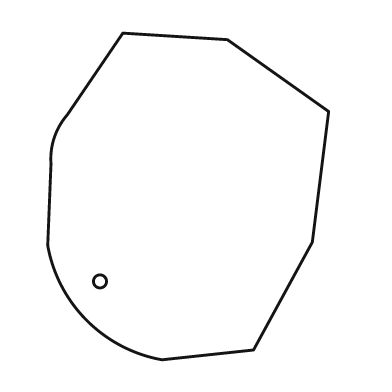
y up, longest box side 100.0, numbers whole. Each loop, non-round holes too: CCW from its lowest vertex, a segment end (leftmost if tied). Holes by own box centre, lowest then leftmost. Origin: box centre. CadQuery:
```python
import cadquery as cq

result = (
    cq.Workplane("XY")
    .moveTo(-8.0, -50.0)
    .lineTo(20.0, -47.0)
    .lineTo(38.0, -14.0)
    .lineTo(43.0, 26.0)
    .lineTo(12.0, 48.0)
    .lineTo(-20.0, 50.0)
    .lineTo(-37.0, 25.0)
    .threePointArc((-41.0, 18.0), (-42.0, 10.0))
    .lineTo(-43.0, -15.0)
    .threePointArc((-31.0, -38.0), (-8.0, -50.0))
    .close()
    .moveTo(-27.0, -26.0)
    .circle(2.0)
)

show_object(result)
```